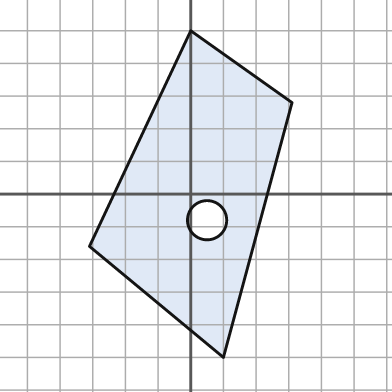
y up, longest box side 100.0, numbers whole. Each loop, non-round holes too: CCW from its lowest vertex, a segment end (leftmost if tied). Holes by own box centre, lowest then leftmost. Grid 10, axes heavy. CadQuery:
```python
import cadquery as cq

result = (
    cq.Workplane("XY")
    .moveTo(10.0, -50.0)
    .lineTo(31.0, 28.0)
    .lineTo(0.0, 50.0)
    .lineTo(-31.0, -16.0)
    .close()
    .moveTo(5.0, -8.0)
    .circle(6.0)
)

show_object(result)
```